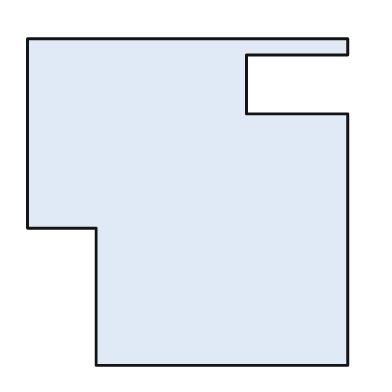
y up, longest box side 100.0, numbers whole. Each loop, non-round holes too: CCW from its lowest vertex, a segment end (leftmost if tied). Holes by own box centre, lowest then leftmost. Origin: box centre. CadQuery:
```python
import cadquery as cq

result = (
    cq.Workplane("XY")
    .moveTo(-28.0, -50.0)
    .lineTo(49.0, -50.0)
    .lineTo(49.0, 27.0)
    .lineTo(18.0, 27.0)
    .lineTo(18.0, 45.0)
    .lineTo(49.0, 45.0)
    .lineTo(49.0, 50.0)
    .lineTo(-49.0, 50.0)
    .lineTo(-49.0, -8.0)
    .lineTo(-28.0, -8.0)
    .close()
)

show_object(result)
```